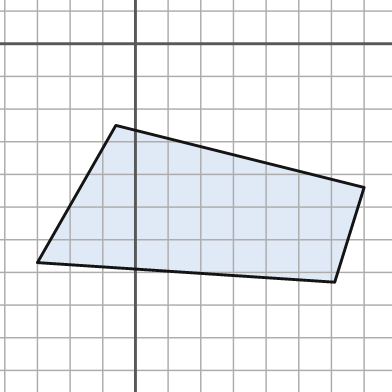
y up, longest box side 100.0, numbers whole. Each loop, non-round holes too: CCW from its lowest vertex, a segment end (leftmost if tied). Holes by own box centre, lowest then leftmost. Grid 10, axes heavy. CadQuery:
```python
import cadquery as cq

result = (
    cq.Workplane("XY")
    .moveTo(61.0, -73.0)
    .lineTo(70.0, -44.0)
    .lineTo(-6.0, -25.0)
    .lineTo(-30.0, -67.0)
    .close()
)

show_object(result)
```